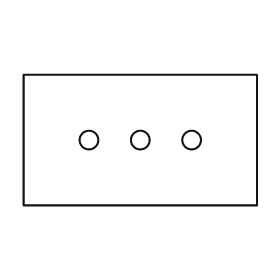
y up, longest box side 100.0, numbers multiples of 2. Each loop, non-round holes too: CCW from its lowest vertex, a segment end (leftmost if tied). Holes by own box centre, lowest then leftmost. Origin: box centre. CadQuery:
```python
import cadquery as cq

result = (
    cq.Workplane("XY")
    .moveTo(-50.0, -28.0)
    .lineTo(50.0, -28.0)
    .lineTo(50.0, 28.0)
    .lineTo(-50.0, 28.0)
    .close()
    .moveTo(-22.0, 0.0)
    .circle(4.0)
    .moveTo(0.0, 0.0)
    .circle(4.0)
    .moveTo(22.0, 0.0)
    .circle(4.0)
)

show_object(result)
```